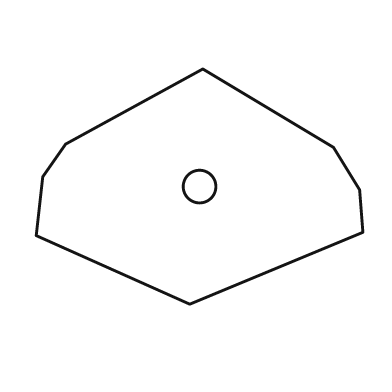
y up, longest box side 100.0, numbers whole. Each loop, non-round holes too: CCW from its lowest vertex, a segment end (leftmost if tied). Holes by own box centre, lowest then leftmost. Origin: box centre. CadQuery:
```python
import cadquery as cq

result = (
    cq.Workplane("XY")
    .moveTo(-3.0, -36.0)
    .lineTo(50.0, -14.0)
    .lineTo(49.0, -1.0)
    .lineTo(41.0, 12.0)
    .lineTo(1.0, 36.0)
    .lineTo(-41.0, 13.0)
    .lineTo(-48.0, 3.0)
    .lineTo(-50.0, -15.0)
    .close()
    .moveTo(0.0, 0.0)
    .circle(5.0)
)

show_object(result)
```